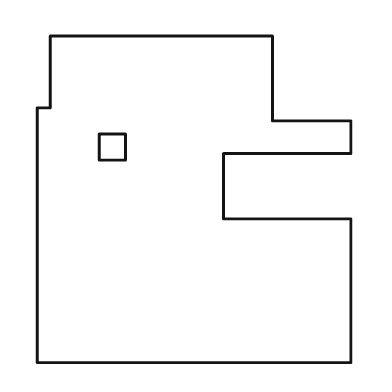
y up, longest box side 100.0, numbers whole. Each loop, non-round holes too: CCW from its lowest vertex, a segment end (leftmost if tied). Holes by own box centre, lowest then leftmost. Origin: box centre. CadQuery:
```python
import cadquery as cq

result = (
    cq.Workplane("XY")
    .moveTo(-48.0, -50.0)
    .lineTo(48.0, -50.0)
    .lineTo(48.0, -6.0)
    .lineTo(9.0, -6.0)
    .lineTo(9.0, 14.0)
    .lineTo(48.0, 14.0)
    .lineTo(48.0, 24.0)
    .lineTo(24.0, 24.0)
    .lineTo(24.0, 50.0)
    .lineTo(-44.0, 50.0)
    .lineTo(-44.0, 28.0)
    .lineTo(-48.0, 28.0)
    .close()
    .moveTo(-29.0, 12.0)
    .lineTo(-21.0, 12.0)
    .lineTo(-21.0, 20.0)
    .lineTo(-29.0, 20.0)
    .close()
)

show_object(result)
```